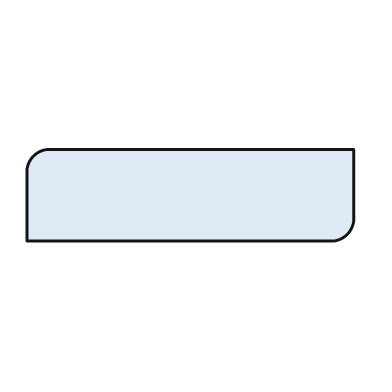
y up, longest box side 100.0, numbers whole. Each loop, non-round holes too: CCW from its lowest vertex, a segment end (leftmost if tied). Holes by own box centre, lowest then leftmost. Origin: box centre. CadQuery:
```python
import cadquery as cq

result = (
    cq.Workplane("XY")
    .moveTo(-50.0, -14.0)
    .lineTo(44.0, -14.0)
    .threePointArc((48.0, -12.0), (50.0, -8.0))
    .lineTo(50.0, 14.0)
    .lineTo(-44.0, 14.0)
    .threePointArc((-48.0, 12.0), (-50.0, 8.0))
    .close()
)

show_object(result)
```